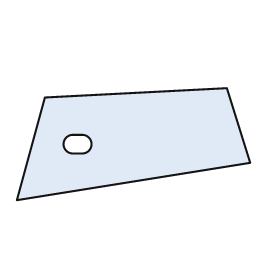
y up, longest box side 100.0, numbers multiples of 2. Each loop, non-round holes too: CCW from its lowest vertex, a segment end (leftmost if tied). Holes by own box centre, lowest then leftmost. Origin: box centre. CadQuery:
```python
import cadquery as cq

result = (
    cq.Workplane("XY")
    .moveTo(-50.0, -24.0)
    .lineTo(50.0, -8.0)
    .lineTo(40.0, 24.0)
    .lineTo(-38.0, 20.0)
    .close()
    .moveTo(-26.0, -4.0)
    .lineTo(-22.0, -4.0)
    .threePointArc((-18.0, 0.0), (-22.0, 4.0))
    .lineTo(-26.0, 4.0)
    .threePointArc((-30.0, 0.0), (-26.0, -4.0))
    .close()
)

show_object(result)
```